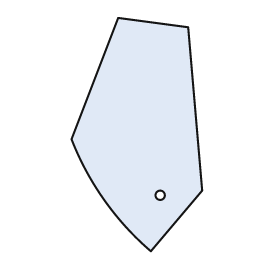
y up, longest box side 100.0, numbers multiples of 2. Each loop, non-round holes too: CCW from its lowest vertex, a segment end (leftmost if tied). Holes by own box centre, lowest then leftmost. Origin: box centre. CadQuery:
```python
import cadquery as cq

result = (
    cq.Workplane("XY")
    .moveTo(6.0, -50.0)
    .lineTo(28.0, -24.0)
    .lineTo(22.0, 46.0)
    .lineTo(-8.0, 50.0)
    .lineTo(-28.0, -2.0)
    .threePointArc((-14.0, -28.0), (6.0, -50.0))
    .close()
    .moveTo(10.0, -26.0)
    .circle(2.0)
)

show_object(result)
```